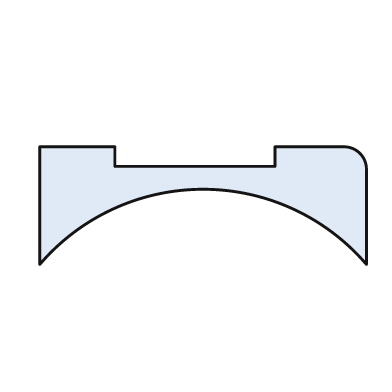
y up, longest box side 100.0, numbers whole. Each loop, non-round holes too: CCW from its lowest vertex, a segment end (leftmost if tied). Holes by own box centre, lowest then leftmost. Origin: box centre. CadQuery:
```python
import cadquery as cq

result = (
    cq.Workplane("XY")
    .moveTo(-50.0, -18.0)
    .threePointArc((0.0, 5.0), (50.0, -18.0))
    .lineTo(50.0, 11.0)
    .threePointArc((48.0, 16.0), (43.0, 18.0))
    .lineTo(22.0, 18.0)
    .lineTo(22.0, 12.0)
    .lineTo(-27.0, 12.0)
    .lineTo(-27.0, 18.0)
    .lineTo(-50.0, 18.0)
    .close()
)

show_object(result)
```